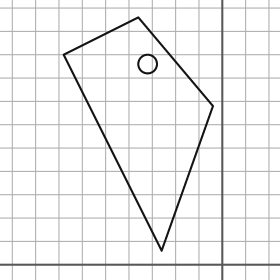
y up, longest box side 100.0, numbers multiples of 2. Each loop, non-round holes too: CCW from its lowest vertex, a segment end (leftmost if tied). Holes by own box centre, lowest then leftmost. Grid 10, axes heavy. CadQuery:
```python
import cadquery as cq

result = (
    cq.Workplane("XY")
    .moveTo(-26.0, 6.0)
    .lineTo(-4.0, 68.0)
    .lineTo(-36.0, 106.0)
    .lineTo(-68.0, 90.0)
    .close()
    .moveTo(-32.0, 86.0)
    .circle(4.0)
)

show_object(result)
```